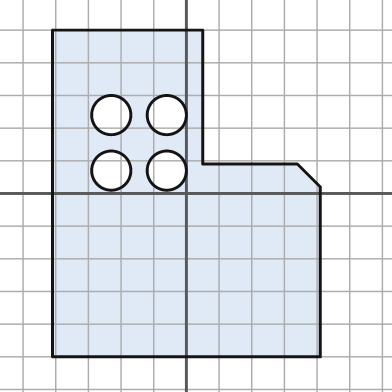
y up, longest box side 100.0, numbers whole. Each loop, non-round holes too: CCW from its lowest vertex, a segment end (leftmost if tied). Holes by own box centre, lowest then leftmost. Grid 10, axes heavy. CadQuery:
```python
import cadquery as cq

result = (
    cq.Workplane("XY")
    .moveTo(-41.0, -50.0)
    .lineTo(41.0, -50.0)
    .lineTo(41.0, 2.0)
    .lineTo(34.0, 9.0)
    .lineTo(5.0, 9.0)
    .lineTo(5.0, 50.0)
    .lineTo(-41.0, 50.0)
    .close()
    .moveTo(-23.0, 7.0)
    .circle(6.0)
    .moveTo(-6.0, 7.0)
    .circle(6.0)
    .moveTo(-23.0, 24.0)
    .circle(6.0)
    .moveTo(-6.0, 24.0)
    .circle(6.0)
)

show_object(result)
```